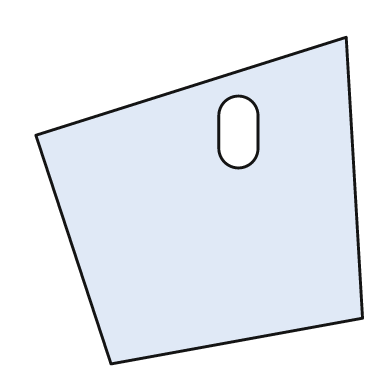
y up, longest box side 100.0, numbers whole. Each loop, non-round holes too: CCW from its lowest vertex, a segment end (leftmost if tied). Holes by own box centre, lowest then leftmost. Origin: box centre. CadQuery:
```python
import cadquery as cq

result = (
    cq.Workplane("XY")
    .moveTo(-27.0, -50.0)
    .lineTo(50.0, -36.0)
    .lineTo(45.0, 50.0)
    .lineTo(-50.0, 20.0)
    .close()
    .moveTo(6.0, 16.0)
    .threePointArc((12.0, 10.0), (18.0, 16.0))
    .lineTo(18.0, 26.0)
    .threePointArc((12.0, 32.0), (6.0, 26.0))
    .close()
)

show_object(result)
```